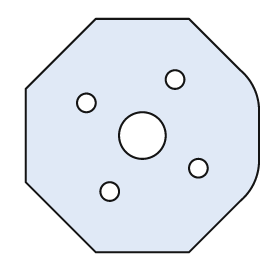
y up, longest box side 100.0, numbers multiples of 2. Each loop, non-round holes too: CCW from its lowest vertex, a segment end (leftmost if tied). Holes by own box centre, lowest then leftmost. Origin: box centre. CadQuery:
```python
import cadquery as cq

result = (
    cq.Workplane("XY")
    .moveTo(-20.0, -50.0)
    .lineTo(20.0, -50.0)
    .lineTo(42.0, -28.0)
    .threePointArc((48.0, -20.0), (50.0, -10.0))
    .lineTo(50.0, 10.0)
    .threePointArc((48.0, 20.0), (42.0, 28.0))
    .lineTo(20.0, 50.0)
    .lineTo(-20.0, 50.0)
    .lineTo(-50.0, 20.0)
    .lineTo(-50.0, -20.0)
    .close()
    .moveTo(-14.0, -24.0)
    .circle(4.0)
    .moveTo(24.0, -14.0)
    .circle(4.0)
    .moveTo(0.0, 0.0)
    .circle(10.0)
    .moveTo(-24.0, 14.0)
    .circle(4.0)
    .moveTo(14.0, 24.0)
    .circle(4.0)
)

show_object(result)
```